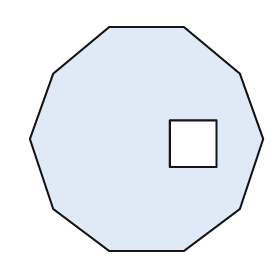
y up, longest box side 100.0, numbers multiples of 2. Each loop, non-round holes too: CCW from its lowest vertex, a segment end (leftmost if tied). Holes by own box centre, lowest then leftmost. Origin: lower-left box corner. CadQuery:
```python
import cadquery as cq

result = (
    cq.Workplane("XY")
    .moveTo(34.0, 0.0)
    .lineTo(66.0, 0.0)
    .lineTo(90.0, 18.0)
    .lineTo(100.0, 48.0)
    .lineTo(90.0, 76.0)
    .lineTo(66.0, 96.0)
    .lineTo(34.0, 96.0)
    .lineTo(10.0, 76.0)
    .lineTo(0.0, 48.0)
    .lineTo(10.0, 18.0)
    .close()
    .moveTo(60.0, 36.0)
    .lineTo(80.0, 36.0)
    .lineTo(80.0, 56.0)
    .lineTo(60.0, 56.0)
    .close()
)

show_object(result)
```